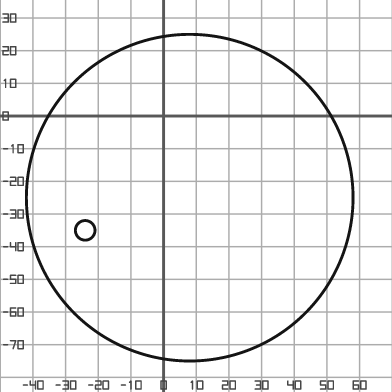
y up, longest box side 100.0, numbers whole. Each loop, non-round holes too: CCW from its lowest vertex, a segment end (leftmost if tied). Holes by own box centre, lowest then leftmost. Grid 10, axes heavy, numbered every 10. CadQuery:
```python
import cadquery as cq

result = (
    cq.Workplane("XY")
    .moveTo(8.0, -25.0)
    .circle(50.0)
    .moveTo(-24.0, -35.0)
    .circle(3.0)
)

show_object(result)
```